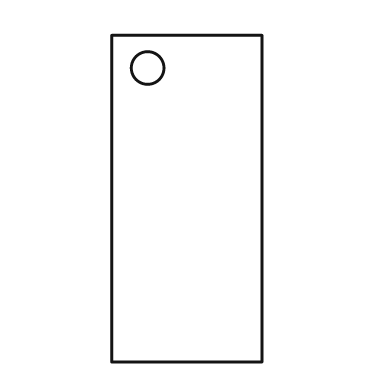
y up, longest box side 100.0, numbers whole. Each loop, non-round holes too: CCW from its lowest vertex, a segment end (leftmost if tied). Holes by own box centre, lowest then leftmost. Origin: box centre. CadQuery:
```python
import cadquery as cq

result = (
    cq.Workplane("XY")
    .moveTo(-23.0, -50.0)
    .lineTo(23.0, -50.0)
    .lineTo(23.0, 50.0)
    .lineTo(-23.0, 50.0)
    .close()
    .moveTo(-12.0, 40.0)
    .circle(5.0)
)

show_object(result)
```